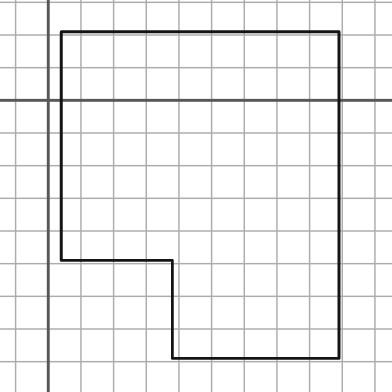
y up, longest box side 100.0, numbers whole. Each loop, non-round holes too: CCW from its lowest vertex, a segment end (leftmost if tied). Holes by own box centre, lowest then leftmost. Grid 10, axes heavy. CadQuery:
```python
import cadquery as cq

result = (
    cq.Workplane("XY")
    .moveTo(38.0, -79.0)
    .lineTo(89.0, -79.0)
    .lineTo(89.0, 21.0)
    .lineTo(4.0, 21.0)
    .lineTo(4.0, -49.0)
    .lineTo(38.0, -49.0)
    .close()
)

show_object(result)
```